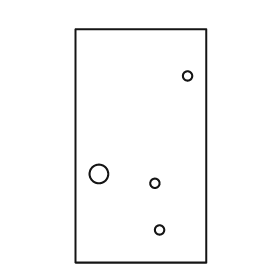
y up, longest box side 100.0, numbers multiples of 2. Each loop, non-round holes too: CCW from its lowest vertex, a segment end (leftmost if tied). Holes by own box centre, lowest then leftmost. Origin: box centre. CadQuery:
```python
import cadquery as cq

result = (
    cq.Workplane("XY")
    .moveTo(-28.0, -50.0)
    .lineTo(28.0, -50.0)
    .lineTo(28.0, 50.0)
    .lineTo(-28.0, 50.0)
    .close()
    .moveTo(8.0, -36.0)
    .circle(2.0)
    .moveTo(6.0, -16.0)
    .circle(2.0)
    .moveTo(-18.0, -12.0)
    .circle(4.0)
    .moveTo(20.0, 30.0)
    .circle(2.0)
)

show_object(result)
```